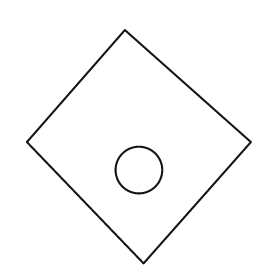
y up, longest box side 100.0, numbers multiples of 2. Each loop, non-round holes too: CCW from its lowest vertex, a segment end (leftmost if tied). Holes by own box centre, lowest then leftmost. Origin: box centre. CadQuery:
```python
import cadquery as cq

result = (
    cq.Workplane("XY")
    .moveTo(2.0, -50.0)
    .lineTo(48.0, 2.0)
    .lineTo(-6.0, 50.0)
    .lineTo(-48.0, 2.0)
    .close()
    .moveTo(0.0, -10.0)
    .circle(10.0)
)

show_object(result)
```